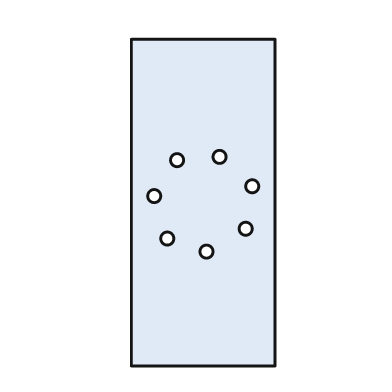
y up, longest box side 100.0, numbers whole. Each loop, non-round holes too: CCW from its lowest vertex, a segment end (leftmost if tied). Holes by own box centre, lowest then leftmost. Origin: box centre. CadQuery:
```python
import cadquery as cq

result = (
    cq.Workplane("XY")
    .moveTo(-22.0, -50.0)
    .lineTo(22.0, -50.0)
    .lineTo(22.0, 50.0)
    .lineTo(-22.0, 50.0)
    .close()
    .moveTo(1.0, -15.0)
    .circle(2.0)
    .moveTo(-11.0, -11.0)
    .circle(2.0)
    .moveTo(13.0, -8.0)
    .circle(2.0)
    .moveTo(-15.0, 2.0)
    .circle(2.0)
    .moveTo(15.0, 5.0)
    .circle(2.0)
    .moveTo(-8.0, 13.0)
    .circle(2.0)
    .moveTo(5.0, 14.0)
    .circle(2.0)
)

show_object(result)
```